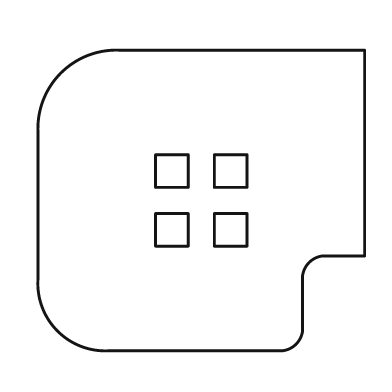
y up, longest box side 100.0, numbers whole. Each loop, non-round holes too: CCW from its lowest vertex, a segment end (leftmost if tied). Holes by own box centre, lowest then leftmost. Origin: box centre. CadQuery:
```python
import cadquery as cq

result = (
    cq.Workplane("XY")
    .moveTo(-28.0, -46.0)
    .lineTo(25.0, -46.0)
    .threePointArc((29.0, -44.0), (31.0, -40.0))
    .lineTo(31.0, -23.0)
    .threePointArc((33.0, -19.0), (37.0, -17.0))
    .lineTo(50.0, -17.0)
    .lineTo(50.0, 46.0)
    .lineTo(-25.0, 46.0)
    .threePointArc((-43.0, 39.0), (-50.0, 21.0))
    .lineTo(-50.0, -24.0)
    .threePointArc((-44.0, -40.0), (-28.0, -46.0))
    .close()
    .moveTo(-14.0, -14.0)
    .lineTo(-4.0, -14.0)
    .lineTo(-4.0, -4.0)
    .lineTo(-14.0, -4.0)
    .close()
    .moveTo(4.0, -14.0)
    .lineTo(14.0, -14.0)
    .lineTo(14.0, -4.0)
    .lineTo(4.0, -4.0)
    .close()
    .moveTo(-14.0, 4.0)
    .lineTo(-4.0, 4.0)
    .lineTo(-4.0, 14.0)
    .lineTo(-14.0, 14.0)
    .close()
    .moveTo(4.0, 4.0)
    .lineTo(14.0, 4.0)
    .lineTo(14.0, 14.0)
    .lineTo(4.0, 14.0)
    .close()
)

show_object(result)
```